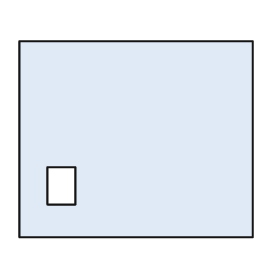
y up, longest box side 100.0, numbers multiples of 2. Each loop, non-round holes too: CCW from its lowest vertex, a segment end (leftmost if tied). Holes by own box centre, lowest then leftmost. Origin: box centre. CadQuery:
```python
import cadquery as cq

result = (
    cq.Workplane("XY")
    .moveTo(-50.0, -42.0)
    .lineTo(50.0, -42.0)
    .lineTo(50.0, 42.0)
    .lineTo(-50.0, 42.0)
    .close()
    .moveTo(-38.0, -28.0)
    .lineTo(-26.0, -28.0)
    .lineTo(-26.0, -12.0)
    .lineTo(-38.0, -12.0)
    .close()
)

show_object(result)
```